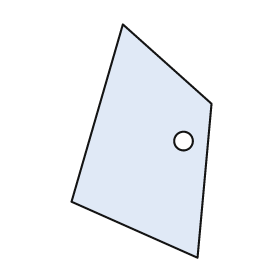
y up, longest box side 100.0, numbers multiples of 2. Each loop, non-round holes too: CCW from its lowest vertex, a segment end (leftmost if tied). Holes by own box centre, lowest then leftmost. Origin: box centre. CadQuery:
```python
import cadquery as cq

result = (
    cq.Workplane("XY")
    .moveTo(24.0, -50.0)
    .lineTo(30.0, 16.0)
    .lineTo(-8.0, 50.0)
    .lineTo(-30.0, -26.0)
    .close()
    .moveTo(18.0, 0.0)
    .circle(4.0)
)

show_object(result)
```